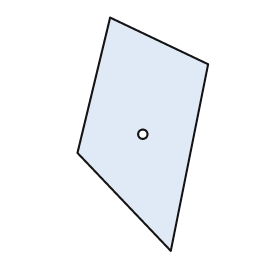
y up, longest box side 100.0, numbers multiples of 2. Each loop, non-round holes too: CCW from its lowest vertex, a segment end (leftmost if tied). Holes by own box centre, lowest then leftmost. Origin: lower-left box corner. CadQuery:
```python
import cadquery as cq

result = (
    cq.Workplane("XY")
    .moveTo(40.0, 0.0)
    .lineTo(56.0, 80.0)
    .lineTo(14.0, 100.0)
    .lineTo(0.0, 42.0)
    .close()
    .moveTo(28.0, 50.0)
    .circle(2.0)
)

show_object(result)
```